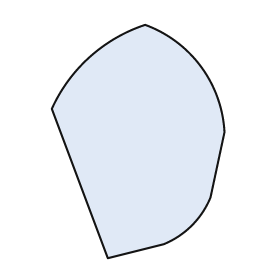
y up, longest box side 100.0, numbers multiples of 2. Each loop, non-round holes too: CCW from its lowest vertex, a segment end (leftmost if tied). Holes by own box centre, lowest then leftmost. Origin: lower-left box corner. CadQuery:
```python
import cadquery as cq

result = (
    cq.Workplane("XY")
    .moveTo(24.0, 0.0)
    .lineTo(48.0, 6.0)
    .threePointArc((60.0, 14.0), (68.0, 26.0))
    .lineTo(74.0, 54.0)
    .threePointArc((64.0, 82.0), (40.0, 100.0))
    .threePointArc((16.0, 86.0), (0.0, 64.0))
    .close()
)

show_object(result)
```